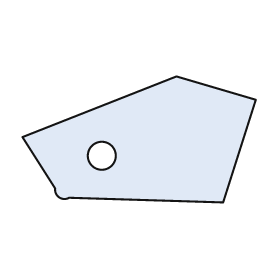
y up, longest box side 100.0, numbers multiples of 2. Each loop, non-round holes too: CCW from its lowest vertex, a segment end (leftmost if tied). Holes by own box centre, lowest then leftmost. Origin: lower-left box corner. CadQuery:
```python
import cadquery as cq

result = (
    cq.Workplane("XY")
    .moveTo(86.0, 0.0)
    .lineTo(100.0, 44.0)
    .lineTo(66.0, 54.0)
    .lineTo(0.0, 28.0)
    .lineTo(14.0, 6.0)
    .threePointArc((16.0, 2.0), (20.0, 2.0))
    .close()
    .moveTo(34.0, 20.0)
    .circle(6.0)
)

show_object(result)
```